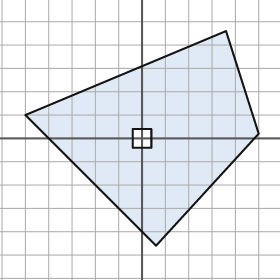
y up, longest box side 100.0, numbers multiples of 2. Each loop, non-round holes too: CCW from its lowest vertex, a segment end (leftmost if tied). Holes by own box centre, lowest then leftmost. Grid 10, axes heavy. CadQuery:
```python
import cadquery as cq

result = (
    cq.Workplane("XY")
    .moveTo(6.0, -46.0)
    .lineTo(50.0, 2.0)
    .lineTo(36.0, 46.0)
    .lineTo(-50.0, 10.0)
    .close()
    .moveTo(-4.0, -4.0)
    .lineTo(4.0, -4.0)
    .lineTo(4.0, 4.0)
    .lineTo(-4.0, 4.0)
    .close()
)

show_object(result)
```